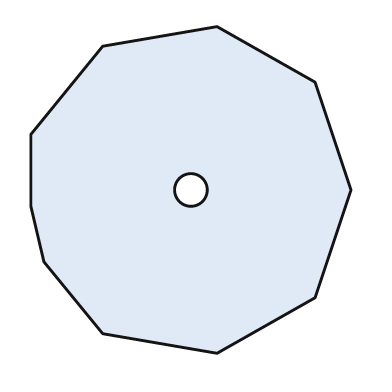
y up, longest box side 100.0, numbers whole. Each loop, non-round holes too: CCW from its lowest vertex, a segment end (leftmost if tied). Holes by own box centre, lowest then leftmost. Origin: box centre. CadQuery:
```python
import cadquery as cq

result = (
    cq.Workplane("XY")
    .moveTo(8.0, -50.0)
    .lineTo(38.0, -33.0)
    .lineTo(49.0, 0.0)
    .lineTo(38.0, 33.0)
    .lineTo(8.0, 50.0)
    .lineTo(-27.0, 44.0)
    .lineTo(-49.0, 17.0)
    .lineTo(-49.0, -5.0)
    .lineTo(-45.0, -22.0)
    .lineTo(-27.0, -44.0)
    .close()
    .moveTo(0.0, 0.0)
    .circle(5.0)
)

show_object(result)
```